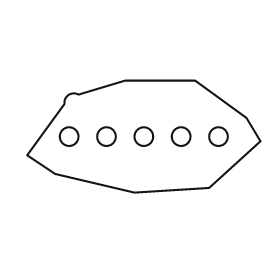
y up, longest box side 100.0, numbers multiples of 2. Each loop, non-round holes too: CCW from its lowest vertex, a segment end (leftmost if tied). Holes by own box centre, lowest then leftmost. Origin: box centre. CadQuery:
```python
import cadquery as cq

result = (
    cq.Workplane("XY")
    .moveTo(-4.0, -24.0)
    .lineTo(28.0, -22.0)
    .lineTo(50.0, -2.0)
    .lineTo(44.0, 8.0)
    .lineTo(22.0, 24.0)
    .lineTo(-8.0, 24.0)
    .lineTo(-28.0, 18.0)
    .threePointArc((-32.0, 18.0), (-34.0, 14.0))
    .lineTo(-50.0, -8.0)
    .lineTo(-38.0, -16.0)
    .close()
    .moveTo(-32.0, 0.0)
    .circle(4.0)
    .moveTo(-16.0, 0.0)
    .circle(4.0)
    .moveTo(0.0, 0.0)
    .circle(4.0)
    .moveTo(16.0, 0.0)
    .circle(4.0)
    .moveTo(32.0, 0.0)
    .circle(4.0)
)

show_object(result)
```